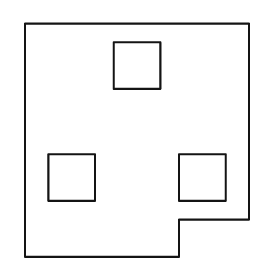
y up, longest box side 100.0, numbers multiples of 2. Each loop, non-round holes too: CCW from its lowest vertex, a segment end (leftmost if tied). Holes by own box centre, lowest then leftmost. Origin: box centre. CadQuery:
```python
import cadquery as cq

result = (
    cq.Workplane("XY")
    .moveTo(-48.0, -50.0)
    .lineTo(18.0, -50.0)
    .lineTo(18.0, -34.0)
    .lineTo(48.0, -34.0)
    .lineTo(48.0, 50.0)
    .lineTo(-48.0, 50.0)
    .close()
    .moveTo(-38.0, -26.0)
    .lineTo(-18.0, -26.0)
    .lineTo(-18.0, -6.0)
    .lineTo(-38.0, -6.0)
    .close()
    .moveTo(18.0, -26.0)
    .lineTo(38.0, -26.0)
    .lineTo(38.0, -6.0)
    .lineTo(18.0, -6.0)
    .close()
    .moveTo(-10.0, 22.0)
    .lineTo(10.0, 22.0)
    .lineTo(10.0, 42.0)
    .lineTo(-10.0, 42.0)
    .close()
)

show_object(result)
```